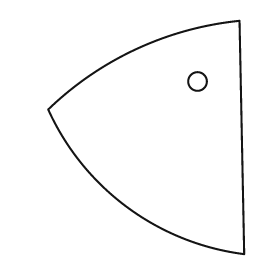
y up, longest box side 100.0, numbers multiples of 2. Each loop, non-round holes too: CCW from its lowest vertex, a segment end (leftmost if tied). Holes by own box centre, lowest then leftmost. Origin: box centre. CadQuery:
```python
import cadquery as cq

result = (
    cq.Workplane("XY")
    .moveTo(42.0, -50.0)
    .lineTo(40.0, 50.0)
    .threePointArc((-4.0, 38.0), (-42.0, 12.0))
    .threePointArc((-8.0, -30.0), (42.0, -50.0))
    .close()
    .moveTo(22.0, 24.0)
    .circle(4.0)
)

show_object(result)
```